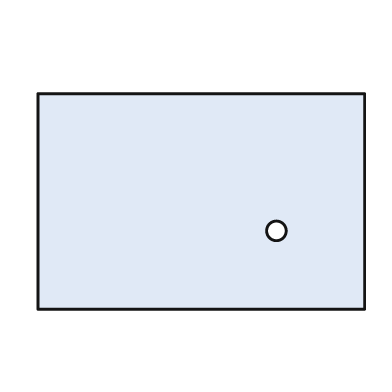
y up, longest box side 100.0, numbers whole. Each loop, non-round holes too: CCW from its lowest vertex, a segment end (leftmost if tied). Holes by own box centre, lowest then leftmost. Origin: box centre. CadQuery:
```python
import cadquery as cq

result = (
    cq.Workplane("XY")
    .moveTo(-50.0, -33.0)
    .lineTo(50.0, -33.0)
    .lineTo(50.0, 33.0)
    .lineTo(-50.0, 33.0)
    .close()
    .moveTo(23.0, -9.0)
    .circle(3.0)
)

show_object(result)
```